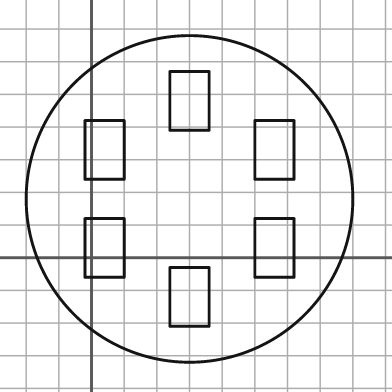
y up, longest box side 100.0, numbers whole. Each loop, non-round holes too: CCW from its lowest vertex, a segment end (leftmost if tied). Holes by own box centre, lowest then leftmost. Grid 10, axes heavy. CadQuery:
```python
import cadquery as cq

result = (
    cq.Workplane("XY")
    .moveTo(30.0, 18.0)
    .circle(50.0)
    .moveTo(24.0, -21.0)
    .lineTo(36.0, -21.0)
    .lineTo(36.0, -3.0)
    .lineTo(24.0, -3.0)
    .close()
    .moveTo(-2.0, -6.0)
    .lineTo(10.0, -6.0)
    .lineTo(10.0, 12.0)
    .lineTo(-2.0, 12.0)
    .close()
    .moveTo(50.0, -6.0)
    .lineTo(62.0, -6.0)
    .lineTo(62.0, 12.0)
    .lineTo(50.0, 12.0)
    .close()
    .moveTo(-2.0, 24.0)
    .lineTo(10.0, 24.0)
    .lineTo(10.0, 42.0)
    .lineTo(-2.0, 42.0)
    .close()
    .moveTo(50.0, 24.0)
    .lineTo(62.0, 24.0)
    .lineTo(62.0, 42.0)
    .lineTo(50.0, 42.0)
    .close()
    .moveTo(24.0, 39.0)
    .lineTo(36.0, 39.0)
    .lineTo(36.0, 57.0)
    .lineTo(24.0, 57.0)
    .close()
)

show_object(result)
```